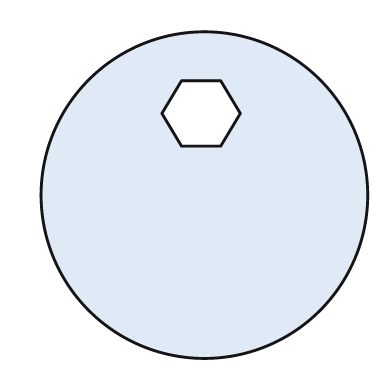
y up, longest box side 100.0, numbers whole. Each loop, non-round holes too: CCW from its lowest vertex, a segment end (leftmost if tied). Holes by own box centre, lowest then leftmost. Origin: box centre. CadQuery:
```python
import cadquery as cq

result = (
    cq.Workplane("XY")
    .moveTo(0.0, 0.0)
    .circle(50.0)
    .moveTo(-7.0, 15.0)
    .lineTo(5.0, 15.0)
    .lineTo(11.0, 25.0)
    .lineTo(5.0, 35.0)
    .lineTo(-7.0, 35.0)
    .lineTo(-13.0, 25.0)
    .close()
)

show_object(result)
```